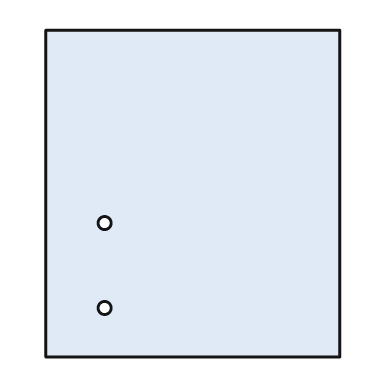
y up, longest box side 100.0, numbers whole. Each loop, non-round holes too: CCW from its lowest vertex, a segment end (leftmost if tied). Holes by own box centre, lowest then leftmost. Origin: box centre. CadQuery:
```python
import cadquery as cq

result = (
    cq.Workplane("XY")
    .moveTo(-45.0, -50.0)
    .lineTo(45.0, -50.0)
    .lineTo(45.0, 50.0)
    .lineTo(-45.0, 50.0)
    .close()
    .moveTo(-27.0, -35.0)
    .circle(2.0)
    .moveTo(-27.0, -9.0)
    .circle(2.0)
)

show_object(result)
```